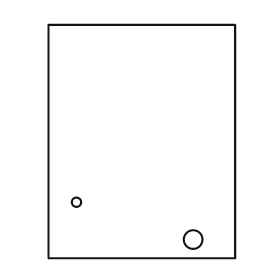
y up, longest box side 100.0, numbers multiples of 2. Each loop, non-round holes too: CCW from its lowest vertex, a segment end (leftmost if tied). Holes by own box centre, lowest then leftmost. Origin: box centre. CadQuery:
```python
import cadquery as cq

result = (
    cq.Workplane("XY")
    .moveTo(-40.0, -50.0)
    .lineTo(40.0, -50.0)
    .lineTo(40.0, 50.0)
    .lineTo(-40.0, 50.0)
    .close()
    .moveTo(22.0, -42.0)
    .circle(4.0)
    .moveTo(-28.0, -26.0)
    .circle(2.0)
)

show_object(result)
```